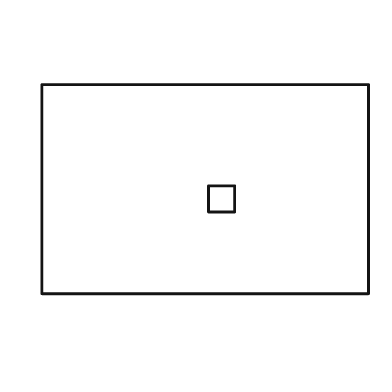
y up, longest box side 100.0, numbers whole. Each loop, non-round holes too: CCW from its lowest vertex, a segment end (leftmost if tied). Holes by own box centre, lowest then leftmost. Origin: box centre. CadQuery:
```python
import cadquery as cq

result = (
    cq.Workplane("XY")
    .moveTo(-50.0, -32.0)
    .lineTo(50.0, -32.0)
    .lineTo(50.0, 32.0)
    .lineTo(-50.0, 32.0)
    .close()
    .moveTo(1.0, -7.0)
    .lineTo(9.0, -7.0)
    .lineTo(9.0, 1.0)
    .lineTo(1.0, 1.0)
    .close()
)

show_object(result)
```